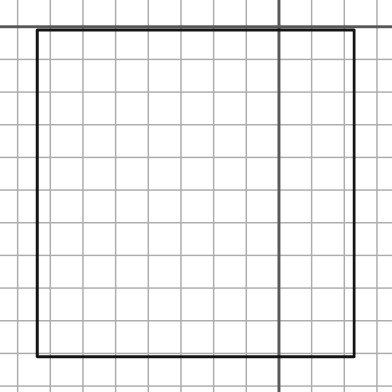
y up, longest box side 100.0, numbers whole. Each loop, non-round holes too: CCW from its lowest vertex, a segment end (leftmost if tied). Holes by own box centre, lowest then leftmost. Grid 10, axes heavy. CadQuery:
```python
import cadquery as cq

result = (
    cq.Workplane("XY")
    .moveTo(-74.0, -101.0)
    .lineTo(23.0, -101.0)
    .lineTo(23.0, -1.0)
    .lineTo(-74.0, -1.0)
    .close()
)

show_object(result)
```